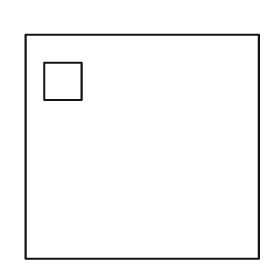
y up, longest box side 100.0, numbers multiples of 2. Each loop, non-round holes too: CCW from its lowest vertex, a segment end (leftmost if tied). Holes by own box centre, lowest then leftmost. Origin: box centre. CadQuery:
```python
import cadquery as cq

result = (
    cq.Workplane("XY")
    .moveTo(-50.0, -48.0)
    .lineTo(50.0, -48.0)
    .lineTo(50.0, 48.0)
    .lineTo(-50.0, 48.0)
    .close()
    .moveTo(-42.0, 20.0)
    .lineTo(-26.0, 20.0)
    .lineTo(-26.0, 36.0)
    .lineTo(-42.0, 36.0)
    .close()
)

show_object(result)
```